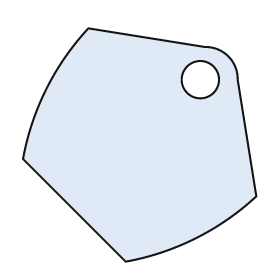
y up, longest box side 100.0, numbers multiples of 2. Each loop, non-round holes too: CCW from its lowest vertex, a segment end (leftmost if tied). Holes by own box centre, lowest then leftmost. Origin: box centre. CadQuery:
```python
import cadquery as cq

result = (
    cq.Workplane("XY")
    .moveTo(-6.0, -50.0)
    .threePointArc((24.0, -40.0), (50.0, -22.0))
    .lineTo(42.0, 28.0)
    .threePointArc((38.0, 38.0), (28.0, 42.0))
    .lineTo(-22.0, 50.0)
    .threePointArc((-40.0, 24.0), (-50.0, -6.0))
    .close()
    .moveTo(26.0, 28.0)
    .circle(8.0)
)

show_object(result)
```